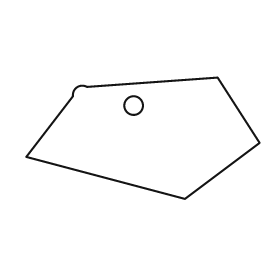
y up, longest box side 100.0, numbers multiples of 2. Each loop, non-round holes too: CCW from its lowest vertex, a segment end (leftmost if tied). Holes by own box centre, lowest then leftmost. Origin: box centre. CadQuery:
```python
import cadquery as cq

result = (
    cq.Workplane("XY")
    .moveTo(18.0, -26.0)
    .lineTo(50.0, -2.0)
    .lineTo(32.0, 26.0)
    .lineTo(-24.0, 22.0)
    .threePointArc((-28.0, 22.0), (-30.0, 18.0))
    .lineTo(-50.0, -8.0)
    .close()
    .moveTo(-4.0, 14.0)
    .circle(4.0)
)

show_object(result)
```